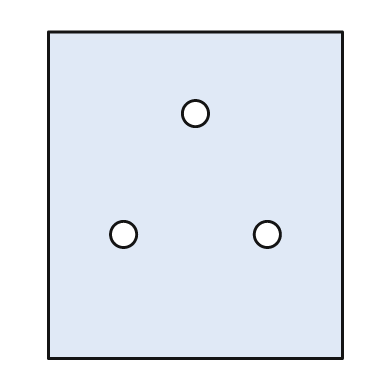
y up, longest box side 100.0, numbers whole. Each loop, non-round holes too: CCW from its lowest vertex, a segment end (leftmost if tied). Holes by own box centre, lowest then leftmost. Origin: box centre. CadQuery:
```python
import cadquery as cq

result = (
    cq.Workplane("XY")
    .moveTo(-45.0, -50.0)
    .lineTo(45.0, -50.0)
    .lineTo(45.0, 50.0)
    .lineTo(-45.0, 50.0)
    .close()
    .moveTo(-22.0, -12.0)
    .circle(4.0)
    .moveTo(22.0, -12.0)
    .circle(4.0)
    .moveTo(0.0, 25.0)
    .circle(4.0)
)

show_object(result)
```